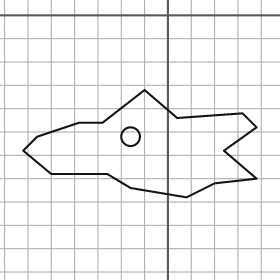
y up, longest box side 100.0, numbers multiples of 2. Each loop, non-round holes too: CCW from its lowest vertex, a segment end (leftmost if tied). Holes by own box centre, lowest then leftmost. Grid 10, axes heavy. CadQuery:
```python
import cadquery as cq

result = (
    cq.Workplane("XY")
    .moveTo(8.0, -78.0)
    .lineTo(20.0, -72.0)
    .lineTo(38.0, -70.0)
    .lineTo(24.0, -58.0)
    .lineTo(38.0, -48.0)
    .lineTo(32.0, -42.0)
    .lineTo(4.0, -44.0)
    .lineTo(-10.0, -32.0)
    .lineTo(-28.0, -46.0)
    .lineTo(-38.0, -46.0)
    .lineTo(-56.0, -52.0)
    .lineTo(-62.0, -58.0)
    .lineTo(-50.0, -68.0)
    .lineTo(-26.0, -68.0)
    .lineTo(-16.0, -74.0)
    .close()
    .moveTo(-16.0, -52.0)
    .circle(4.0)
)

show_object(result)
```